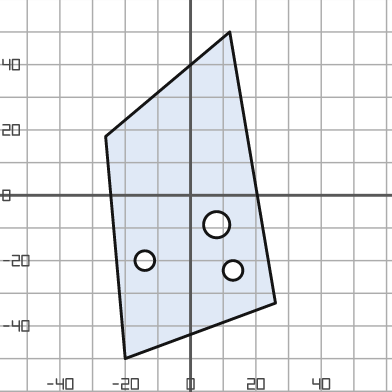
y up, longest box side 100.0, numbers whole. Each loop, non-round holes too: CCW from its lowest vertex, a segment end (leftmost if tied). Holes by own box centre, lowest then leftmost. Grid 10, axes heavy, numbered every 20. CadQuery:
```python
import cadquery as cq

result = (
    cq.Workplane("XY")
    .moveTo(-20.0, -50.0)
    .lineTo(26.0, -33.0)
    .lineTo(12.0, 50.0)
    .lineTo(-26.0, 18.0)
    .close()
    .moveTo(13.0, -23.0)
    .circle(3.0)
    .moveTo(-14.0, -20.0)
    .circle(3.0)
    .moveTo(8.0, -9.0)
    .circle(4.0)
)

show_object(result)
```